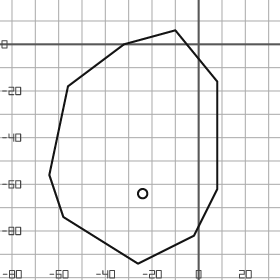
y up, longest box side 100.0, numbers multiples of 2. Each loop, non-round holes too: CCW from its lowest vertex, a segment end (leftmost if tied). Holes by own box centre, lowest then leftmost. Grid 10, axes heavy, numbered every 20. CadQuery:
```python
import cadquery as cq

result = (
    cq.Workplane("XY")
    .moveTo(-26.0, -94.0)
    .lineTo(-2.0, -82.0)
    .lineTo(8.0, -62.0)
    .lineTo(8.0, -16.0)
    .lineTo(-10.0, 6.0)
    .lineTo(-32.0, 0.0)
    .lineTo(-56.0, -18.0)
    .lineTo(-64.0, -56.0)
    .lineTo(-58.0, -74.0)
    .close()
    .moveTo(-24.0, -64.0)
    .circle(2.0)
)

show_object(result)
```